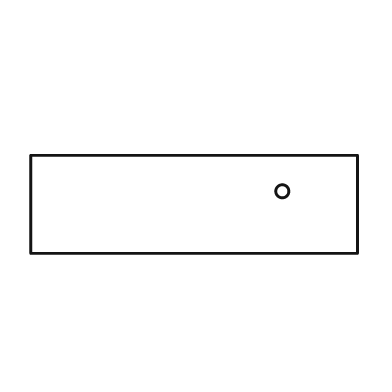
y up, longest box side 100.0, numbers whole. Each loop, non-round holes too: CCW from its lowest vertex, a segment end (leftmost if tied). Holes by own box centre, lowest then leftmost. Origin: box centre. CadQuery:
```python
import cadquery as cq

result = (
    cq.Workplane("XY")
    .moveTo(-50.0, -15.0)
    .lineTo(50.0, -15.0)
    .lineTo(50.0, 15.0)
    .lineTo(-50.0, 15.0)
    .close()
    .moveTo(27.0, 4.0)
    .circle(2.0)
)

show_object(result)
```